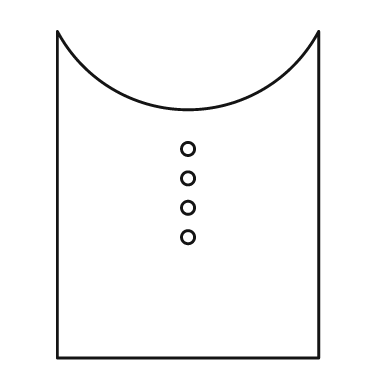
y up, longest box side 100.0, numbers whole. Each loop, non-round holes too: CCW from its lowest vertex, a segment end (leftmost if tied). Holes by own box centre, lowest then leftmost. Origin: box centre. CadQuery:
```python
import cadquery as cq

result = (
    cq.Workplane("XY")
    .moveTo(-40.0, -50.0)
    .lineTo(40.0, -50.0)
    .lineTo(40.0, 50.0)
    .threePointArc((0.0, 26.0), (-40.0, 50.0))
    .close()
    .moveTo(0.0, -13.0)
    .circle(2.0)
    .moveTo(0.0, -4.0)
    .circle(2.0)
    .moveTo(0.0, 5.0)
    .circle(2.0)
    .moveTo(0.0, 14.0)
    .circle(2.0)
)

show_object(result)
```